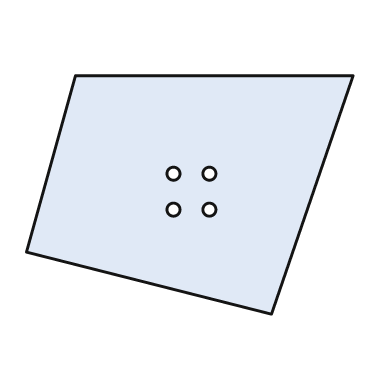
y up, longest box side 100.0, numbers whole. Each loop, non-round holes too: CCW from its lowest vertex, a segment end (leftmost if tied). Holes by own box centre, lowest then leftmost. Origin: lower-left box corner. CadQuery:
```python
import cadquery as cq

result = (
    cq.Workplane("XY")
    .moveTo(75.0, 0.0)
    .lineTo(100.0, 73.0)
    .lineTo(15.0, 73.0)
    .lineTo(0.0, 19.0)
    .close()
    .moveTo(45.0, 32.0)
    .circle(2.0)
    .moveTo(56.0, 32.0)
    .circle(2.0)
    .moveTo(45.0, 43.0)
    .circle(2.0)
    .moveTo(56.0, 43.0)
    .circle(2.0)
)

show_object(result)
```